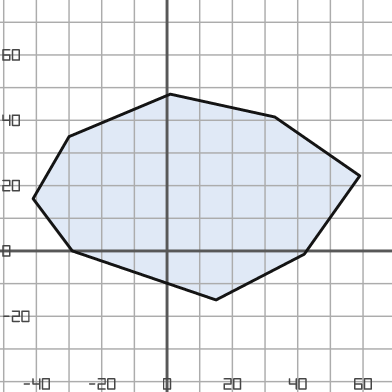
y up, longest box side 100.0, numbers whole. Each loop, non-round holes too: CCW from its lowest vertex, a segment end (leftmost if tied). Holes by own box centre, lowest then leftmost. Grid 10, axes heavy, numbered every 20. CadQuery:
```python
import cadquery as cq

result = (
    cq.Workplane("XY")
    .moveTo(15.0, -15.0)
    .lineTo(42.0, -1.0)
    .lineTo(59.0, 23.0)
    .lineTo(33.0, 41.0)
    .lineTo(1.0, 48.0)
    .lineTo(-30.0, 35.0)
    .lineTo(-41.0, 16.0)
    .lineTo(-29.0, 0.0)
    .close()
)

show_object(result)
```